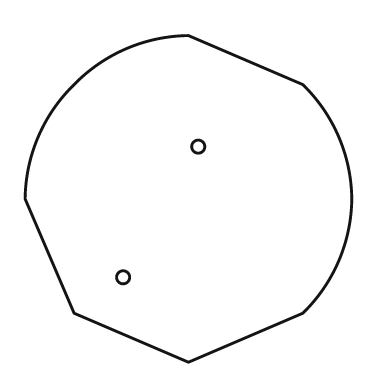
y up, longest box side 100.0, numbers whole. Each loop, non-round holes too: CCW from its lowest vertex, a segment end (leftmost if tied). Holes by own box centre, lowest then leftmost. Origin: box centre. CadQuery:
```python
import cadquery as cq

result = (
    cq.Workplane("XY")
    .moveTo(0.0, -50.0)
    .lineTo(35.0, -35.0)
    .threePointArc((46.0, -19.0), (50.0, 0.0))
    .threePointArc((46.0, 19.0), (35.0, 35.0))
    .lineTo(0.0, 50.0)
    .threePointArc((-19.0, 46.0), (-35.0, 35.0))
    .threePointArc((-46.0, 19.0), (-50.0, 0.0))
    .lineTo(-35.0, -35.0)
    .close()
    .moveTo(-20.0, -24.0)
    .circle(2.0)
    .moveTo(3.0, 16.0)
    .circle(2.0)
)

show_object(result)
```